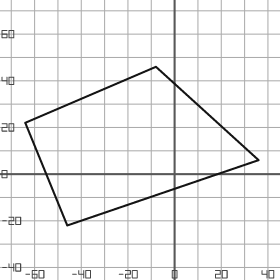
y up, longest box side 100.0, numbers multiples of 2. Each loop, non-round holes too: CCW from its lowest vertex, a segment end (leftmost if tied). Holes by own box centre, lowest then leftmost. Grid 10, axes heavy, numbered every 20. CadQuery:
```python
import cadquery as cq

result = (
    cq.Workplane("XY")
    .moveTo(-46.0, -22.0)
    .lineTo(36.0, 6.0)
    .lineTo(-8.0, 46.0)
    .lineTo(-64.0, 22.0)
    .close()
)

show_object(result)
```